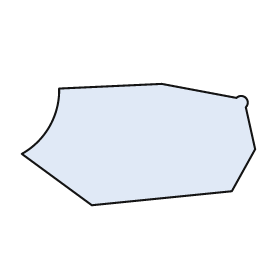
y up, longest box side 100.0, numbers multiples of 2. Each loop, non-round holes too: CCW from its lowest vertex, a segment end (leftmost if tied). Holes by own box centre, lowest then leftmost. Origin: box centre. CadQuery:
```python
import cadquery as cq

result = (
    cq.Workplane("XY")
    .moveTo(-20.0, -26.0)
    .lineTo(40.0, -20.0)
    .lineTo(50.0, -2.0)
    .lineTo(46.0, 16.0)
    .threePointArc((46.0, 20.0), (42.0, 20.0))
    .lineTo(10.0, 26.0)
    .lineTo(-34.0, 24.0)
    .threePointArc((-38.0, 8.0), (-50.0, -4.0))
    .close()
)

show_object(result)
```